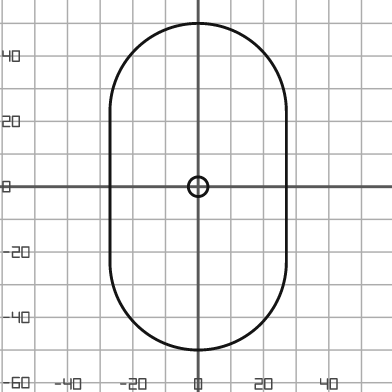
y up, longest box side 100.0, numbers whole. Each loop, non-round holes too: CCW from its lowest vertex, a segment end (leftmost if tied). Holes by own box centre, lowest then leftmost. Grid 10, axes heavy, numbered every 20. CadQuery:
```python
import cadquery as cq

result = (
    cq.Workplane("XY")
    .moveTo(-27.0, -23.0)
    .threePointArc((0.0, -50.0), (27.0, -23.0))
    .lineTo(27.0, 23.0)
    .threePointArc((0.0, 50.0), (-27.0, 23.0))
    .close()
    .moveTo(0.0, 0.0)
    .circle(3.0)
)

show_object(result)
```